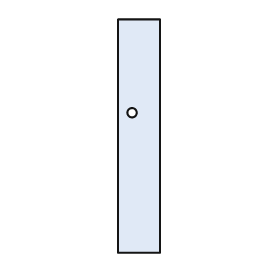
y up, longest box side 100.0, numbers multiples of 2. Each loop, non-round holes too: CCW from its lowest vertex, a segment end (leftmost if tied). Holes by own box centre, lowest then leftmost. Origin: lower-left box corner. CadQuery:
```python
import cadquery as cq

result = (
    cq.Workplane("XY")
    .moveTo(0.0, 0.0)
    .lineTo(18.0, 0.0)
    .lineTo(18.0, 100.0)
    .lineTo(0.0, 100.0)
    .close()
    .moveTo(6.0, 60.0)
    .circle(2.0)
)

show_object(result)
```